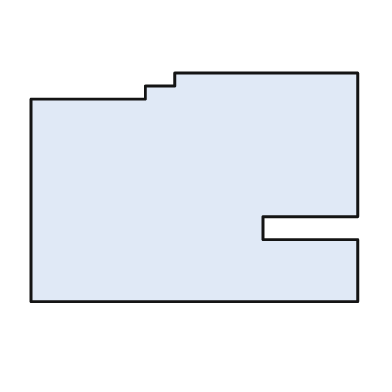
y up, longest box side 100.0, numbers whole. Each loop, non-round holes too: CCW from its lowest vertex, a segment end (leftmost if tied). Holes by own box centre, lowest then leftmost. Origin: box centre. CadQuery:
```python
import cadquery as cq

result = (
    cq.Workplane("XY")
    .moveTo(-50.0, -35.0)
    .lineTo(50.0, -35.0)
    .lineTo(50.0, -16.0)
    .lineTo(21.0, -16.0)
    .lineTo(21.0, -9.0)
    .lineTo(50.0, -9.0)
    .lineTo(50.0, 35.0)
    .lineTo(-6.0, 35.0)
    .lineTo(-6.0, 31.0)
    .lineTo(-15.0, 31.0)
    .lineTo(-15.0, 27.0)
    .lineTo(-50.0, 27.0)
    .close()
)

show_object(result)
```